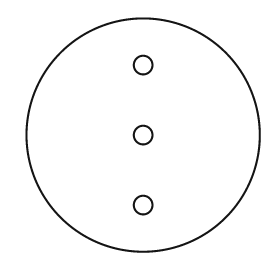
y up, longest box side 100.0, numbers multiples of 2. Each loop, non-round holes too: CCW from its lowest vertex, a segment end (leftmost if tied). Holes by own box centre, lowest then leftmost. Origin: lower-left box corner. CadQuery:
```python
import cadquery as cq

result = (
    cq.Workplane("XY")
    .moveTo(50.0, 50.0)
    .circle(50.0)
    .moveTo(50.0, 20.0)
    .circle(4.0)
    .moveTo(50.0, 50.0)
    .circle(4.0)
    .moveTo(50.0, 80.0)
    .circle(4.0)
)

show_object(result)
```